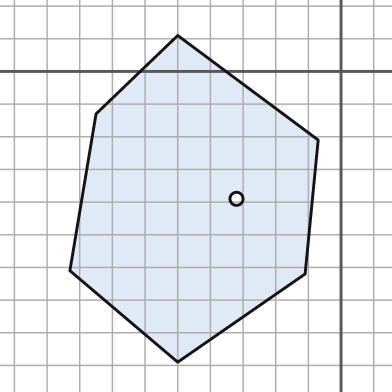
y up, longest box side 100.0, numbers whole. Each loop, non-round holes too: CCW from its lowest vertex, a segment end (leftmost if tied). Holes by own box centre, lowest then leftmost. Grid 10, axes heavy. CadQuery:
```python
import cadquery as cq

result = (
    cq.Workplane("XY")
    .moveTo(-50.0, -89.0)
    .lineTo(-11.0, -62.0)
    .lineTo(-7.0, -21.0)
    .lineTo(-50.0, 11.0)
    .lineTo(-75.0, -13.0)
    .lineTo(-83.0, -61.0)
    .close()
    .moveTo(-32.0, -39.0)
    .circle(2.0)
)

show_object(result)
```